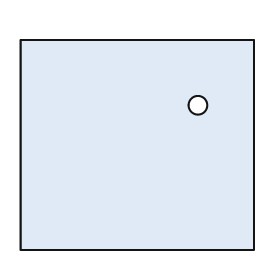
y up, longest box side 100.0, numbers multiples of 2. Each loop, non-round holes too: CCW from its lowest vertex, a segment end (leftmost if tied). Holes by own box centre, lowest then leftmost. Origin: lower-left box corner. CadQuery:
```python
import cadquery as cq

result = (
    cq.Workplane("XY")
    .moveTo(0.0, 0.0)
    .lineTo(100.0, 0.0)
    .lineTo(100.0, 90.0)
    .lineTo(0.0, 90.0)
    .close()
    .moveTo(76.0, 62.0)
    .circle(4.0)
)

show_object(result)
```